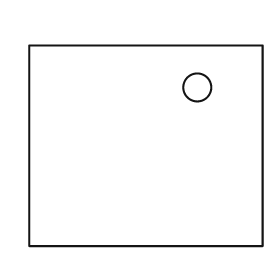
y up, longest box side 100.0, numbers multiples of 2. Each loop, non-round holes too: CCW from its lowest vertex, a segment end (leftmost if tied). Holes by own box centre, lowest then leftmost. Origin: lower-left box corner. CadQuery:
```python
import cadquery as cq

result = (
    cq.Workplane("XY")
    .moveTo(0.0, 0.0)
    .lineTo(100.0, 0.0)
    .lineTo(100.0, 86.0)
    .lineTo(0.0, 86.0)
    .close()
    .moveTo(72.0, 68.0)
    .circle(6.0)
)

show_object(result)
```